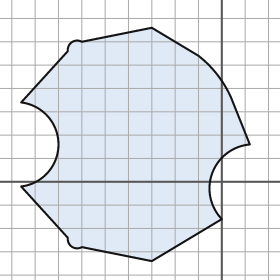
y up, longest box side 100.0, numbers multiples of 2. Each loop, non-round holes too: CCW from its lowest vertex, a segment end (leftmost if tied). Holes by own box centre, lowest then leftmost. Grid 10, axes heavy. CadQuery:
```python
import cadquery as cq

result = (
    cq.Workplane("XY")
    .moveTo(-30.0, -34.0)
    .lineTo(0.0, -16.0)
    .threePointArc((-4.0, 4.0), (12.0, 16.0))
    .lineTo(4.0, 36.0)
    .threePointArc((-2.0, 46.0), (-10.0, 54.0))
    .lineTo(-30.0, 66.0)
    .lineTo(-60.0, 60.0)
    .threePointArc((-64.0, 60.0), (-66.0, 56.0))
    .lineTo(-86.0, 34.0)
    .threePointArc((-70.0, 16.0), (-86.0, -2.0))
    .lineTo(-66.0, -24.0)
    .threePointArc((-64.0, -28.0), (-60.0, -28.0))
    .close()
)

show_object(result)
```